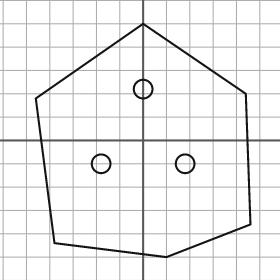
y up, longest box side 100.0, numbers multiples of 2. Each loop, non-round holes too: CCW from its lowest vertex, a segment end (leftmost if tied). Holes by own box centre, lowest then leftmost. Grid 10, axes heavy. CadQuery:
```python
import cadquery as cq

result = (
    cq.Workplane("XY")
    .moveTo(10.0, -50.0)
    .lineTo(46.0, -36.0)
    .lineTo(44.0, 20.0)
    .lineTo(0.0, 50.0)
    .lineTo(-46.0, 18.0)
    .lineTo(-38.0, -44.0)
    .close()
    .moveTo(-18.0, -10.0)
    .circle(4.0)
    .moveTo(18.0, -10.0)
    .circle(4.0)
    .moveTo(0.0, 22.0)
    .circle(4.0)
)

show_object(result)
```